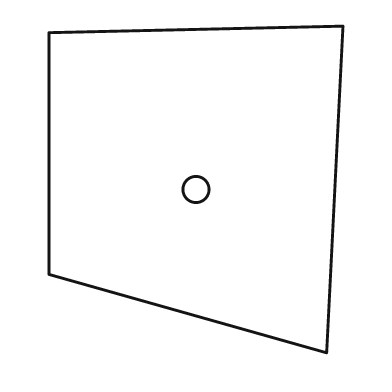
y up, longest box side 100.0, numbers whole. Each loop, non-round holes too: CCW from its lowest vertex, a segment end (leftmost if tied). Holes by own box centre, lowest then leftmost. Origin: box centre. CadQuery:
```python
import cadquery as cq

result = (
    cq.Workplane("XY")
    .moveTo(40.0, -50.0)
    .lineTo(45.0, 50.0)
    .lineTo(-45.0, 48.0)
    .lineTo(-45.0, -26.0)
    .close()
    .moveTo(0.0, 0.0)
    .circle(4.0)
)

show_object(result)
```